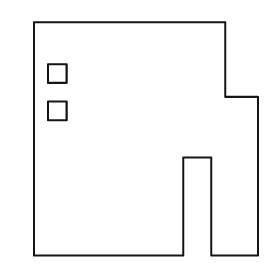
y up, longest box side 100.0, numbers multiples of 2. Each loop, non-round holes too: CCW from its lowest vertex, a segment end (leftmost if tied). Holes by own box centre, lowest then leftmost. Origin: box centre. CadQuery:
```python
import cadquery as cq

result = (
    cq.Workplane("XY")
    .moveTo(-48.0, -50.0)
    .lineTo(16.0, -50.0)
    .lineTo(16.0, -8.0)
    .lineTo(28.0, -8.0)
    .lineTo(28.0, -50.0)
    .lineTo(48.0, -50.0)
    .lineTo(48.0, 18.0)
    .lineTo(34.0, 18.0)
    .lineTo(34.0, 50.0)
    .lineTo(-48.0, 50.0)
    .close()
    .moveTo(-42.0, 8.0)
    .lineTo(-34.0, 8.0)
    .lineTo(-34.0, 16.0)
    .lineTo(-42.0, 16.0)
    .close()
    .moveTo(-42.0, 24.0)
    .lineTo(-34.0, 24.0)
    .lineTo(-34.0, 32.0)
    .lineTo(-42.0, 32.0)
    .close()
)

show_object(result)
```